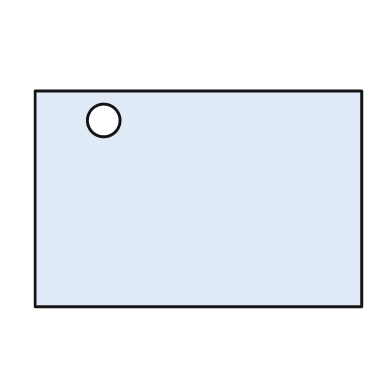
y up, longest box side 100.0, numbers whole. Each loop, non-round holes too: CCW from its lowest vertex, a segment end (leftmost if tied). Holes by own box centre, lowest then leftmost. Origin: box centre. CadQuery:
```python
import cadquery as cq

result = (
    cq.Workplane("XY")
    .moveTo(-50.0, -33.0)
    .lineTo(50.0, -33.0)
    .lineTo(50.0, 33.0)
    .lineTo(-50.0, 33.0)
    .close()
    .moveTo(-29.0, 24.0)
    .circle(5.0)
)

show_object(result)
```